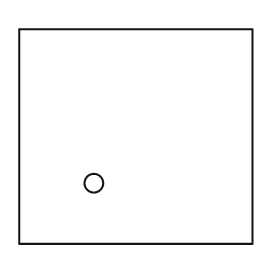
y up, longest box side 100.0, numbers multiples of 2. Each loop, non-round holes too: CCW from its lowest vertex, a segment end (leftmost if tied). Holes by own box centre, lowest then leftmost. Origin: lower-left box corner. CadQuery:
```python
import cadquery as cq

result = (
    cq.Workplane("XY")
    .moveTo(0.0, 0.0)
    .lineTo(100.0, 0.0)
    .lineTo(100.0, 92.0)
    .lineTo(0.0, 92.0)
    .close()
    .moveTo(32.0, 26.0)
    .circle(4.0)
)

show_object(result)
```